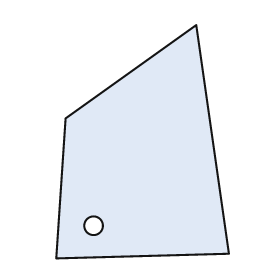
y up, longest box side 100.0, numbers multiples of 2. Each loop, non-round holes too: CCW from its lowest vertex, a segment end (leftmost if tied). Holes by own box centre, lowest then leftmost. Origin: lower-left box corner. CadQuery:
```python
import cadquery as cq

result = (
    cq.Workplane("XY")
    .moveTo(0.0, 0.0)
    .lineTo(74.0, 2.0)
    .lineTo(60.0, 100.0)
    .lineTo(4.0, 60.0)
    .close()
    .moveTo(16.0, 14.0)
    .circle(4.0)
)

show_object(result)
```